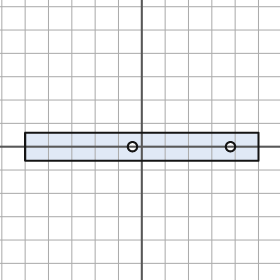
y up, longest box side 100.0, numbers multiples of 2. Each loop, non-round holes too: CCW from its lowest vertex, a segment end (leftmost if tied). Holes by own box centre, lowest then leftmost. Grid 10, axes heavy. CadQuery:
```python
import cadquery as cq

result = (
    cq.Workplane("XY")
    .moveTo(-50.0, -6.0)
    .lineTo(50.0, -6.0)
    .lineTo(50.0, 6.0)
    .lineTo(-50.0, 6.0)
    .close()
    .moveTo(-4.0, 0.0)
    .circle(2.0)
    .moveTo(38.0, 0.0)
    .circle(2.0)
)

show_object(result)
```